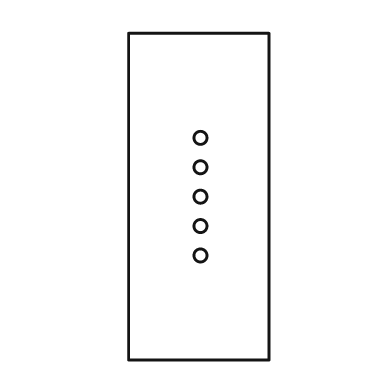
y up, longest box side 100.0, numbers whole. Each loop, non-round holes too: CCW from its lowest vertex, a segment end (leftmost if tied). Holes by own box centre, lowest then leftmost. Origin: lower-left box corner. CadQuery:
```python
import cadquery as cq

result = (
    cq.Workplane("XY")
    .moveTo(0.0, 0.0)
    .lineTo(43.0, 0.0)
    .lineTo(43.0, 100.0)
    .lineTo(0.0, 100.0)
    .close()
    .moveTo(22.0, 32.0)
    .circle(2.0)
    .moveTo(22.0, 41.0)
    .circle(2.0)
    .moveTo(22.0, 50.0)
    .circle(2.0)
    .moveTo(22.0, 59.0)
    .circle(2.0)
    .moveTo(22.0, 68.0)
    .circle(2.0)
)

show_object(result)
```